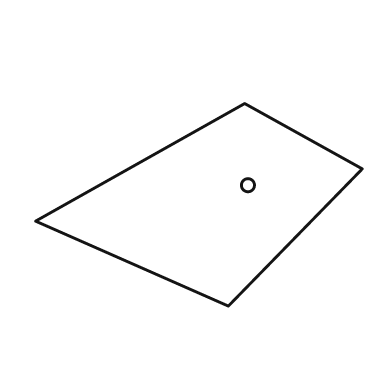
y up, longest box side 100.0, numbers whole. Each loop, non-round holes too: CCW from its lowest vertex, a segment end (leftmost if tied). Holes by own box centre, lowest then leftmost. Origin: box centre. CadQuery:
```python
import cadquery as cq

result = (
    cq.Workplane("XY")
    .moveTo(9.0, -31.0)
    .lineTo(50.0, 11.0)
    .lineTo(14.0, 31.0)
    .lineTo(-50.0, -5.0)
    .close()
    .moveTo(15.0, 6.0)
    .circle(2.0)
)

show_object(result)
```